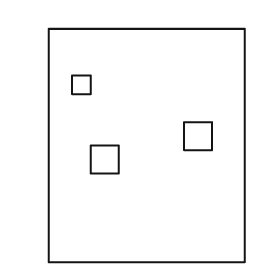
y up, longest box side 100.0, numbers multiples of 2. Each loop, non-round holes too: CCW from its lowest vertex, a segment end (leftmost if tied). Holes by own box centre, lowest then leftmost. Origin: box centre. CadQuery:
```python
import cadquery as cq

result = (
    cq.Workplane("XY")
    .moveTo(-42.0, -50.0)
    .lineTo(42.0, -50.0)
    .lineTo(42.0, 50.0)
    .lineTo(-42.0, 50.0)
    .close()
    .moveTo(-24.0, -12.0)
    .lineTo(-12.0, -12.0)
    .lineTo(-12.0, 0.0)
    .lineTo(-24.0, 0.0)
    .close()
    .moveTo(16.0, -2.0)
    .lineTo(28.0, -2.0)
    .lineTo(28.0, 10.0)
    .lineTo(16.0, 10.0)
    .close()
    .moveTo(-32.0, 22.0)
    .lineTo(-24.0, 22.0)
    .lineTo(-24.0, 30.0)
    .lineTo(-32.0, 30.0)
    .close()
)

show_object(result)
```